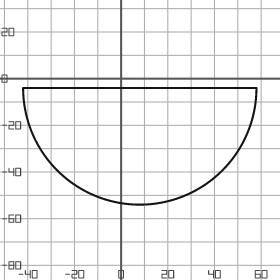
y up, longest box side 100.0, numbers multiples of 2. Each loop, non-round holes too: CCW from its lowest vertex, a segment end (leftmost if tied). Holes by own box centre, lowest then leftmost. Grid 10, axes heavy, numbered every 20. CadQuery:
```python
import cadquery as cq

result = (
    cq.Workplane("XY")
    .moveTo(-42.0, -4.0)
    .threePointArc((8.0, -54.0), (58.0, -4.0))
    .close()
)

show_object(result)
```